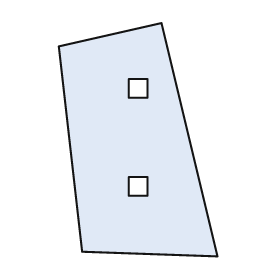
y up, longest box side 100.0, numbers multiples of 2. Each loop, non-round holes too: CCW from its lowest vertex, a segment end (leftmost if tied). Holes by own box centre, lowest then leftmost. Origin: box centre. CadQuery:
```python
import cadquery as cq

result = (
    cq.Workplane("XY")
    .moveTo(34.0, -50.0)
    .lineTo(10.0, 50.0)
    .lineTo(-34.0, 40.0)
    .lineTo(-24.0, -48.0)
    .close()
    .moveTo(-4.0, -24.0)
    .lineTo(4.0, -24.0)
    .lineTo(4.0, -16.0)
    .lineTo(-4.0, -16.0)
    .close()
    .moveTo(-4.0, 18.0)
    .lineTo(4.0, 18.0)
    .lineTo(4.0, 26.0)
    .lineTo(-4.0, 26.0)
    .close()
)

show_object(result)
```